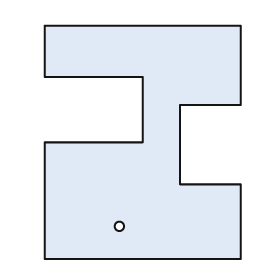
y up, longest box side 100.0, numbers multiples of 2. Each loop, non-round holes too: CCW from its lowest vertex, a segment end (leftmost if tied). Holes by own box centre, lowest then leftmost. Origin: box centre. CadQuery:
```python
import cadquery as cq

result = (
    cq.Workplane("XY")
    .moveTo(-42.0, -50.0)
    .lineTo(42.0, -50.0)
    .lineTo(42.0, -18.0)
    .lineTo(16.0, -18.0)
    .lineTo(16.0, 16.0)
    .lineTo(42.0, 16.0)
    .lineTo(42.0, 50.0)
    .lineTo(-42.0, 50.0)
    .lineTo(-42.0, 28.0)
    .lineTo(0.0, 28.0)
    .lineTo(0.0, 0.0)
    .lineTo(-42.0, 0.0)
    .close()
    .moveTo(-10.0, -36.0)
    .circle(2.0)
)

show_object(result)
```